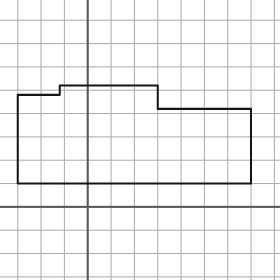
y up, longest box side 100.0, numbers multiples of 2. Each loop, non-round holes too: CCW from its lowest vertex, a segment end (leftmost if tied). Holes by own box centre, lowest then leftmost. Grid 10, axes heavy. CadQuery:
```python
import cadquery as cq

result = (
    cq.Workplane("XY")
    .moveTo(-30.0, 10.0)
    .lineTo(70.0, 10.0)
    .lineTo(70.0, 42.0)
    .lineTo(30.0, 42.0)
    .lineTo(30.0, 52.0)
    .lineTo(-12.0, 52.0)
    .lineTo(-12.0, 48.0)
    .lineTo(-30.0, 48.0)
    .close()
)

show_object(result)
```